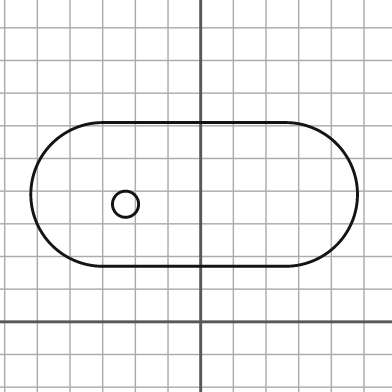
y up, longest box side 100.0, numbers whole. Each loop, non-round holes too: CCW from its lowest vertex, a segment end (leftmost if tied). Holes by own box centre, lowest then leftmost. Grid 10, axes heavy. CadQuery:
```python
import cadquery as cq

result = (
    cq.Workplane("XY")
    .moveTo(-30.0, 17.0)
    .lineTo(26.0, 17.0)
    .threePointArc((48.0, 39.0), (26.0, 61.0))
    .lineTo(-30.0, 61.0)
    .threePointArc((-52.0, 39.0), (-30.0, 17.0))
    .close()
    .moveTo(-23.0, 36.0)
    .circle(4.0)
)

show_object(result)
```